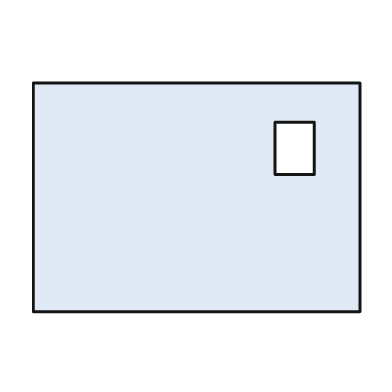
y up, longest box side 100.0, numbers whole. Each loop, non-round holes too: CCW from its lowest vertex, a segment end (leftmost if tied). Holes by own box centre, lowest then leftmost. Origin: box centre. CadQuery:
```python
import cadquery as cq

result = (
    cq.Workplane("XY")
    .moveTo(-50.0, -35.0)
    .lineTo(50.0, -35.0)
    .lineTo(50.0, 35.0)
    .lineTo(-50.0, 35.0)
    .close()
    .moveTo(24.0, 7.0)
    .lineTo(36.0, 7.0)
    .lineTo(36.0, 23.0)
    .lineTo(24.0, 23.0)
    .close()
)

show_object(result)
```